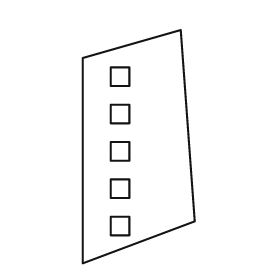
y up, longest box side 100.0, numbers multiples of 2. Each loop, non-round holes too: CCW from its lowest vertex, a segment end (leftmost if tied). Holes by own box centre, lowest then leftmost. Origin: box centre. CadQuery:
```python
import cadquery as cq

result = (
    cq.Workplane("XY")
    .moveTo(-24.0, -50.0)
    .lineTo(24.0, -32.0)
    .lineTo(18.0, 50.0)
    .lineTo(-24.0, 38.0)
    .close()
    .moveTo(-12.0, -38.0)
    .lineTo(-4.0, -38.0)
    .lineTo(-4.0, -30.0)
    .lineTo(-12.0, -30.0)
    .close()
    .moveTo(-12.0, -22.0)
    .lineTo(-4.0, -22.0)
    .lineTo(-4.0, -14.0)
    .lineTo(-12.0, -14.0)
    .close()
    .moveTo(-12.0, -6.0)
    .lineTo(-4.0, -6.0)
    .lineTo(-4.0, 2.0)
    .lineTo(-12.0, 2.0)
    .close()
    .moveTo(-12.0, 10.0)
    .lineTo(-4.0, 10.0)
    .lineTo(-4.0, 18.0)
    .lineTo(-12.0, 18.0)
    .close()
    .moveTo(-12.0, 26.0)
    .lineTo(-4.0, 26.0)
    .lineTo(-4.0, 34.0)
    .lineTo(-12.0, 34.0)
    .close()
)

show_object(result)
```